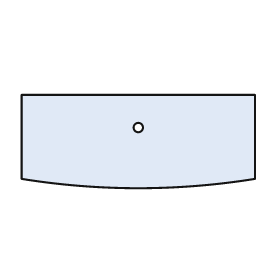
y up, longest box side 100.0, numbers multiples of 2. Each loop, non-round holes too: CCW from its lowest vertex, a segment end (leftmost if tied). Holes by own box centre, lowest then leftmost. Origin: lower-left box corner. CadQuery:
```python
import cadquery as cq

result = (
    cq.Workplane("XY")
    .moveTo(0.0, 4.0)
    .threePointArc((50.0, 0.0), (100.0, 4.0))
    .lineTo(100.0, 40.0)
    .lineTo(0.0, 40.0)
    .close()
    .moveTo(50.0, 26.0)
    .circle(2.0)
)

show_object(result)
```